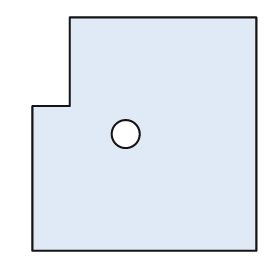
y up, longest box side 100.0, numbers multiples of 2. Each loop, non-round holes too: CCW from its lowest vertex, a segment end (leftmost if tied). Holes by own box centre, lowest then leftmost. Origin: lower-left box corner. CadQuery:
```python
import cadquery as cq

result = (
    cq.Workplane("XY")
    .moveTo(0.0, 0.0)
    .lineTo(96.0, 0.0)
    .lineTo(96.0, 100.0)
    .lineTo(16.0, 100.0)
    .lineTo(16.0, 62.0)
    .lineTo(0.0, 62.0)
    .close()
    .moveTo(40.0, 50.0)
    .circle(6.0)
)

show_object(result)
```